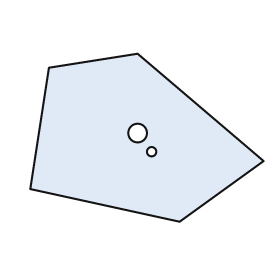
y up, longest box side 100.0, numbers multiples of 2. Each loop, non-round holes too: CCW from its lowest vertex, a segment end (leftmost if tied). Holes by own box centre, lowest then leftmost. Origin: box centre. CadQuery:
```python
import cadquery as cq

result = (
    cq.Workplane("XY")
    .moveTo(14.0, -36.0)
    .lineTo(50.0, -10.0)
    .lineTo(-4.0, 36.0)
    .lineTo(-42.0, 30.0)
    .lineTo(-50.0, -22.0)
    .close()
    .moveTo(2.0, -6.0)
    .circle(2.0)
    .moveTo(-4.0, 2.0)
    .circle(4.0)
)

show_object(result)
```